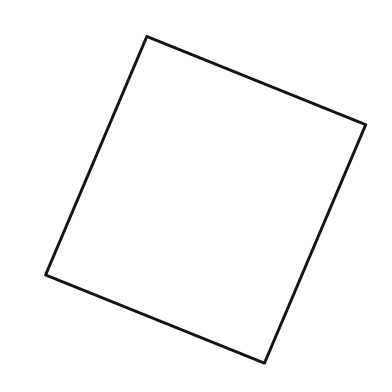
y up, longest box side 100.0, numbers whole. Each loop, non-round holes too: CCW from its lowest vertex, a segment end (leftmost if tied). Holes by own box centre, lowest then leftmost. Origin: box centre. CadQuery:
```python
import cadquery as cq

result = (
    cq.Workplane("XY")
    .moveTo(18.0, -50.0)
    .lineTo(49.0, 23.0)
    .lineTo(-18.0, 50.0)
    .lineTo(-49.0, -23.0)
    .close()
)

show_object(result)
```